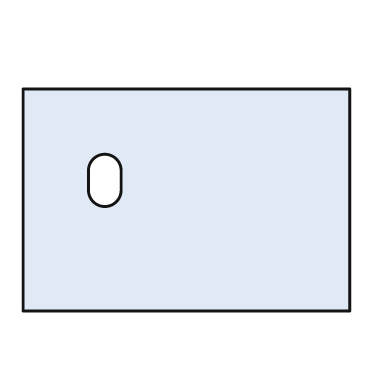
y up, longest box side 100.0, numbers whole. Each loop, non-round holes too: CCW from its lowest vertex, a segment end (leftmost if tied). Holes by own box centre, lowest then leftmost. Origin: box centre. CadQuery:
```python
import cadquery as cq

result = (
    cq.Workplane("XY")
    .moveTo(-50.0, -34.0)
    .lineTo(50.0, -34.0)
    .lineTo(50.0, 34.0)
    .lineTo(-50.0, 34.0)
    .close()
    .moveTo(-30.0, 3.0)
    .threePointArc((-25.0, -2.0), (-20.0, 3.0))
    .lineTo(-20.0, 9.0)
    .threePointArc((-25.0, 14.0), (-30.0, 9.0))
    .close()
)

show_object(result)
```